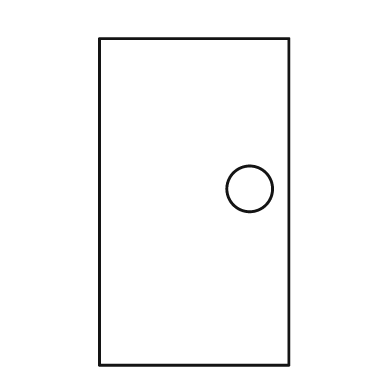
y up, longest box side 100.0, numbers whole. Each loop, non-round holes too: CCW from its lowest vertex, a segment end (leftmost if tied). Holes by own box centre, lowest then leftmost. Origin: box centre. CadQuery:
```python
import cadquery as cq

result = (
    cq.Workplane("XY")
    .moveTo(-29.0, -50.0)
    .lineTo(29.0, -50.0)
    .lineTo(29.0, 50.0)
    .lineTo(-29.0, 50.0)
    .close()
    .moveTo(17.0, 4.0)
    .circle(7.0)
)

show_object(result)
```